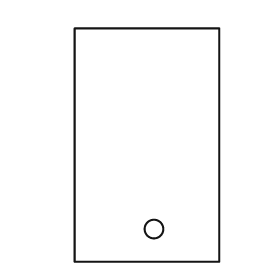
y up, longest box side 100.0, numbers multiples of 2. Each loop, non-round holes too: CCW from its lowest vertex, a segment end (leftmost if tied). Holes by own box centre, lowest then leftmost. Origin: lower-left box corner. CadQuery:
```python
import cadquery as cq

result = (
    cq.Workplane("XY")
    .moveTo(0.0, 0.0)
    .lineTo(62.0, 0.0)
    .lineTo(62.0, 100.0)
    .lineTo(0.0, 100.0)
    .close()
    .moveTo(34.0, 14.0)
    .circle(4.0)
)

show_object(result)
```